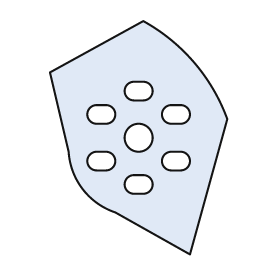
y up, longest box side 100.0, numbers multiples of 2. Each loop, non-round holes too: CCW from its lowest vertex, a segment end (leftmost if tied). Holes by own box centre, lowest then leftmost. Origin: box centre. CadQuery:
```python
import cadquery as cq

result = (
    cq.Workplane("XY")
    .moveTo(22.0, -50.0)
    .lineTo(38.0, 8.0)
    .threePointArc((24.0, 32.0), (2.0, 50.0))
    .lineTo(-38.0, 28.0)
    .lineTo(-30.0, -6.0)
    .threePointArc((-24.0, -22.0), (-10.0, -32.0))
    .close()
    .moveTo(-2.0, -24.0)
    .lineTo(2.0, -24.0)
    .threePointArc((6.0, -20.0), (2.0, -16.0))
    .lineTo(-2.0, -16.0)
    .threePointArc((-6.0, -20.0), (-2.0, -24.0))
    .close()
    .moveTo(-18.0, -14.0)
    .lineTo(-14.0, -14.0)
    .threePointArc((-10.0, -10.0), (-14.0, -6.0))
    .lineTo(-18.0, -6.0)
    .threePointArc((-22.0, -10.0), (-18.0, -14.0))
    .close()
    .moveTo(14.0, -14.0)
    .lineTo(18.0, -14.0)
    .threePointArc((22.0, -10.0), (18.0, -6.0))
    .lineTo(14.0, -6.0)
    .threePointArc((10.0, -10.0), (14.0, -14.0))
    .close()
    .moveTo(0.0, 0.0)
    .circle(6.0)
    .moveTo(-18.0, 6.0)
    .lineTo(-14.0, 6.0)
    .threePointArc((-10.0, 10.0), (-14.0, 14.0))
    .lineTo(-18.0, 14.0)
    .threePointArc((-22.0, 10.0), (-18.0, 6.0))
    .close()
    .moveTo(14.0, 6.0)
    .lineTo(18.0, 6.0)
    .threePointArc((22.0, 10.0), (18.0, 14.0))
    .lineTo(14.0, 14.0)
    .threePointArc((10.0, 10.0), (14.0, 6.0))
    .close()
    .moveTo(-2.0, 16.0)
    .lineTo(2.0, 16.0)
    .threePointArc((6.0, 20.0), (2.0, 24.0))
    .lineTo(-2.0, 24.0)
    .threePointArc((-6.0, 20.0), (-2.0, 16.0))
    .close()
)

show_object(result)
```